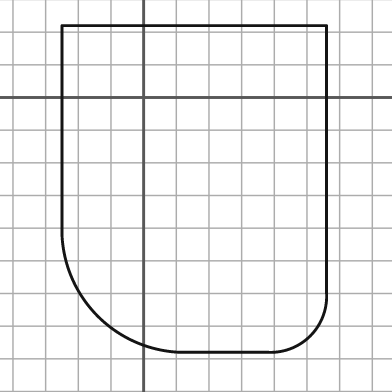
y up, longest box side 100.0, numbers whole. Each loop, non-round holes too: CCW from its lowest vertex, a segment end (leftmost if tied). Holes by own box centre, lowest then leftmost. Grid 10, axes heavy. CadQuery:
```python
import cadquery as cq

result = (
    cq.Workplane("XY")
    .moveTo(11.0, -78.0)
    .lineTo(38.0, -78.0)
    .threePointArc((51.0, -73.0), (56.0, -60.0))
    .lineTo(56.0, 22.0)
    .lineTo(-25.0, 22.0)
    .lineTo(-25.0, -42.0)
    .threePointArc((-14.0, -67.0), (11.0, -78.0))
    .close()
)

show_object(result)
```